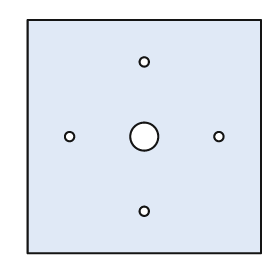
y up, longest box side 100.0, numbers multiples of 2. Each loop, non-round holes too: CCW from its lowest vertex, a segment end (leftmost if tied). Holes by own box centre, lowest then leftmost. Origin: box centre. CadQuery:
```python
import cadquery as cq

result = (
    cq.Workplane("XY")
    .moveTo(-50.0, -50.0)
    .lineTo(50.0, -50.0)
    .lineTo(50.0, 50.0)
    .lineTo(-50.0, 50.0)
    .close()
    .moveTo(0.0, -32.0)
    .circle(2.0)
    .moveTo(-32.0, 0.0)
    .circle(2.0)
    .moveTo(0.0, 0.0)
    .circle(6.0)
    .moveTo(32.0, 0.0)
    .circle(2.0)
    .moveTo(0.0, 32.0)
    .circle(2.0)
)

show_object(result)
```